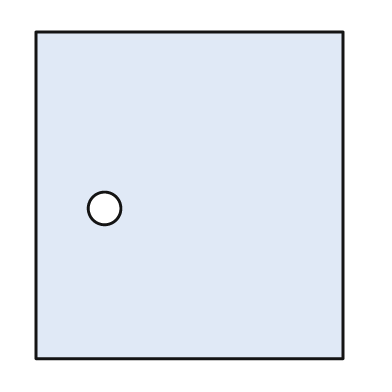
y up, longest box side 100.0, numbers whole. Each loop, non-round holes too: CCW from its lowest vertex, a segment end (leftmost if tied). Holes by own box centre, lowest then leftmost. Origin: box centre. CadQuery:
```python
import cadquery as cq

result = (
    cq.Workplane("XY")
    .moveTo(-47.0, -50.0)
    .lineTo(47.0, -50.0)
    .lineTo(47.0, 50.0)
    .lineTo(-47.0, 50.0)
    .close()
    .moveTo(-26.0, -4.0)
    .circle(5.0)
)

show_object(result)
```